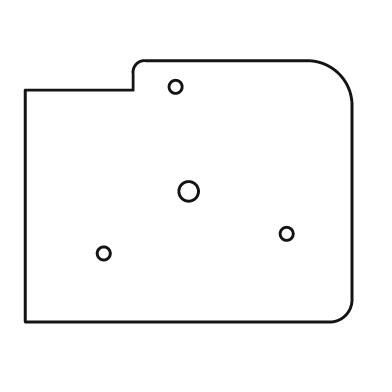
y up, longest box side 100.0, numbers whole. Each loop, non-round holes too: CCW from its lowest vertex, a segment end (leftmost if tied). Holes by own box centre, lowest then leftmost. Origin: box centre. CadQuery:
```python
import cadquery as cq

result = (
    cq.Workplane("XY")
    .moveTo(-50.0, -40.0)
    .lineTo(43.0, -40.0)
    .threePointArc((48.0, -38.0), (50.0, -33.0))
    .lineTo(50.0, 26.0)
    .threePointArc((46.0, 36.0), (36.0, 40.0))
    .lineTo(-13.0, 40.0)
    .threePointArc((-16.0, 39.0), (-17.0, 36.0))
    .lineTo(-17.0, 31.0)
    .lineTo(-50.0, 31.0)
    .close()
    .moveTo(-26.0, -19.0)
    .circle(2.0)
    .moveTo(30.0, -13.0)
    .circle(2.0)
    .moveTo(0.0, 0.0)
    .circle(3.0)
    .moveTo(-4.0, 32.0)
    .circle(2.0)
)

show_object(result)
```